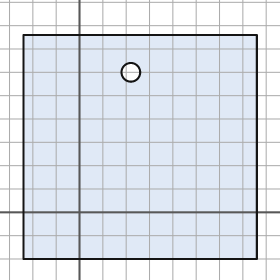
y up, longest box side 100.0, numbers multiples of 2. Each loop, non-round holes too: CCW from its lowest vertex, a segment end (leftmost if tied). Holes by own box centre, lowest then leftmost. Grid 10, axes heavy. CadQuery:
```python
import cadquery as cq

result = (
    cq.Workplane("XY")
    .moveTo(-24.0, -20.0)
    .lineTo(76.0, -20.0)
    .lineTo(76.0, 76.0)
    .lineTo(-24.0, 76.0)
    .close()
    .moveTo(22.0, 60.0)
    .circle(4.0)
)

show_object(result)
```